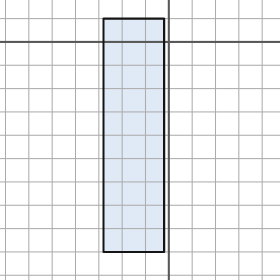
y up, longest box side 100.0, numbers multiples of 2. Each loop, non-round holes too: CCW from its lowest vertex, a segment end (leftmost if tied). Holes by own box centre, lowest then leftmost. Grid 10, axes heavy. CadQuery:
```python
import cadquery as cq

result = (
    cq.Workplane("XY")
    .moveTo(-28.0, -90.0)
    .lineTo(-2.0, -90.0)
    .lineTo(-2.0, 10.0)
    .lineTo(-28.0, 10.0)
    .close()
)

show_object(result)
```